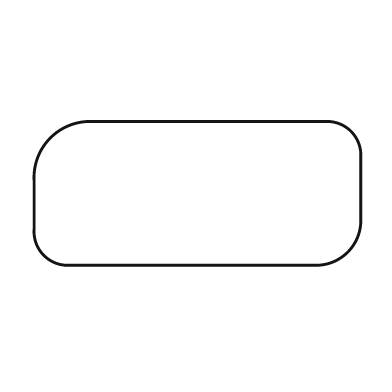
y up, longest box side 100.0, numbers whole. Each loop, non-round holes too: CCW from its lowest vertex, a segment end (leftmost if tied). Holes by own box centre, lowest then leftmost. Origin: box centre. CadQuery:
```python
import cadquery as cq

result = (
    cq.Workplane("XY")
    .moveTo(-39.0, -22.0)
    .lineTo(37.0, -22.0)
    .threePointArc((46.0, -18.0), (50.0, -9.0))
    .lineTo(50.0, 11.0)
    .threePointArc((47.0, 19.0), (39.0, 22.0))
    .lineTo(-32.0, 22.0)
    .threePointArc((-45.0, 17.0), (-50.0, 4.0))
    .lineTo(-50.0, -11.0)
    .threePointArc((-47.0, -19.0), (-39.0, -22.0))
    .close()
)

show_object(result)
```